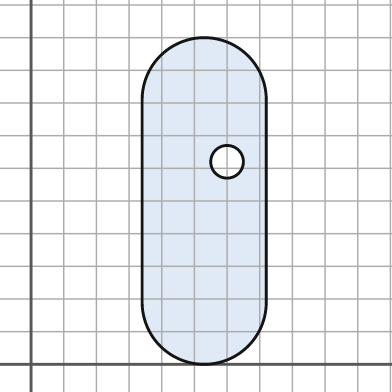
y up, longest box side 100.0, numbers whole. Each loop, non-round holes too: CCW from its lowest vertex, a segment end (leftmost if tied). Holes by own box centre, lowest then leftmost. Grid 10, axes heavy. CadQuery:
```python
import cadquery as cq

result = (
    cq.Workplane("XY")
    .moveTo(34.0, 19.0)
    .threePointArc((53.0, 0.0), (72.0, 19.0))
    .lineTo(72.0, 81.0)
    .threePointArc((53.0, 100.0), (34.0, 81.0))
    .close()
    .moveTo(60.0, 62.0)
    .circle(5.0)
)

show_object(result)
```